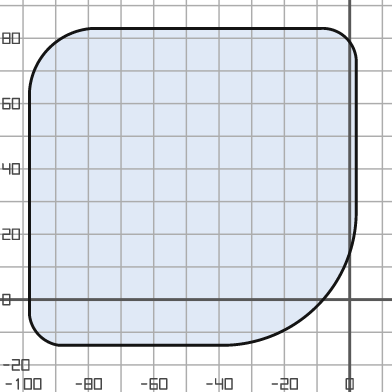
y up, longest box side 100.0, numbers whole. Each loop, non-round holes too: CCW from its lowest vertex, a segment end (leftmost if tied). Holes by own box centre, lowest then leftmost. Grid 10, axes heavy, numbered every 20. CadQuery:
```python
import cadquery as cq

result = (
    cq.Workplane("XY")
    .moveTo(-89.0, -14.0)
    .lineTo(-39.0, -14.0)
    .threePointArc((-10.0, -2.0), (2.0, 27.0))
    .lineTo(2.0, 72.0)
    .threePointArc((-1.0, 80.0), (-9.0, 83.0))
    .lineTo(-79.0, 83.0)
    .threePointArc((-92.0, 77.0), (-98.0, 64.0))
    .lineTo(-98.0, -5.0)
    .threePointArc((-95.0, -11.0), (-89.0, -14.0))
    .close()
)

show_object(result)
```